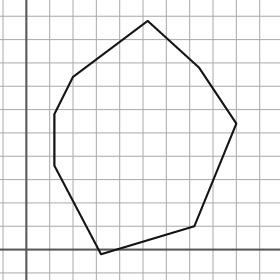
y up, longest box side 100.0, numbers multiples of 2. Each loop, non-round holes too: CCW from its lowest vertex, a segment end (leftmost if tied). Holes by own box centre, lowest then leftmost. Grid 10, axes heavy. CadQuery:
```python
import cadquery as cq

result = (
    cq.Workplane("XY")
    .moveTo(32.0, -2.0)
    .lineTo(72.0, 10.0)
    .lineTo(90.0, 54.0)
    .lineTo(74.0, 78.0)
    .lineTo(52.0, 98.0)
    .lineTo(20.0, 74.0)
    .lineTo(12.0, 58.0)
    .lineTo(12.0, 36.0)
    .close()
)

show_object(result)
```